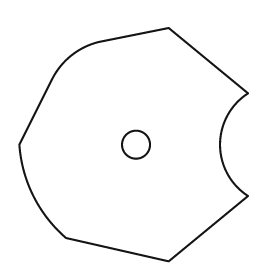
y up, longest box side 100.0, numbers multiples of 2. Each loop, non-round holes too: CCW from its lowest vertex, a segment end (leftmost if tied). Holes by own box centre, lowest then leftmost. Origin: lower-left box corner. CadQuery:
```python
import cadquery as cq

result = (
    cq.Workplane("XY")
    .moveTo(64.0, 0.0)
    .lineTo(98.0, 28.0)
    .threePointArc((86.0, 50.0), (98.0, 72.0))
    .lineTo(64.0, 100.0)
    .lineTo(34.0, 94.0)
    .threePointArc((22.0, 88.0), (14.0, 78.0))
    .lineTo(0.0, 50.0)
    .threePointArc((6.0, 28.0), (20.0, 10.0))
    .close()
    .moveTo(50.0, 50.0)
    .circle(6.0)
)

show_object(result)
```